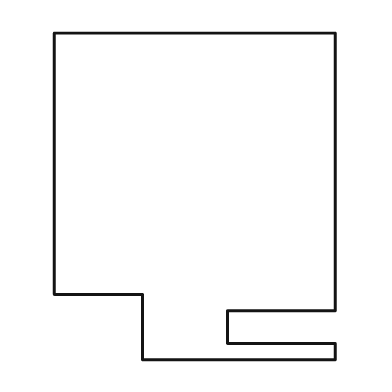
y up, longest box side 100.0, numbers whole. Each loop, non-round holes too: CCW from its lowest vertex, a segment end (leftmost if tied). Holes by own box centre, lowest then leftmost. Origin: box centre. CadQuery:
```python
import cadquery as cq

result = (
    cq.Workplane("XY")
    .moveTo(-16.0, -50.0)
    .lineTo(43.0, -50.0)
    .lineTo(43.0, -45.0)
    .lineTo(10.0, -45.0)
    .lineTo(10.0, -35.0)
    .lineTo(43.0, -35.0)
    .lineTo(43.0, 50.0)
    .lineTo(-43.0, 50.0)
    .lineTo(-43.0, -30.0)
    .lineTo(-16.0, -30.0)
    .close()
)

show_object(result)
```